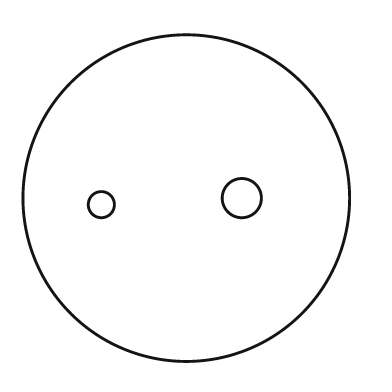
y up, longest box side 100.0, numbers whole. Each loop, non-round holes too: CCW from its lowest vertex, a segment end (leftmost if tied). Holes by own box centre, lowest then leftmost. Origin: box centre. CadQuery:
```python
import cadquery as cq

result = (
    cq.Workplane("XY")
    .moveTo(0.0, 0.0)
    .circle(50.0)
    .moveTo(-26.0, -2.0)
    .circle(4.0)
    .moveTo(17.0, 0.0)
    .circle(6.0)
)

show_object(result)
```